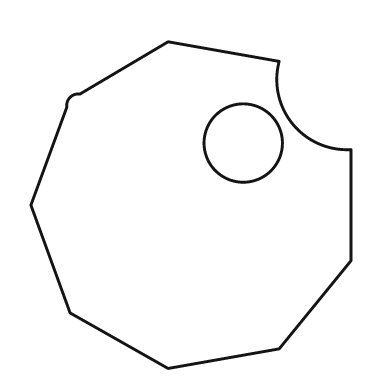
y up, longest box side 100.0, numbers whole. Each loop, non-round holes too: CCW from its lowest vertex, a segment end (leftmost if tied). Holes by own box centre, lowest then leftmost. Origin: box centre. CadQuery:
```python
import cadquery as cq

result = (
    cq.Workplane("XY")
    .moveTo(-7.0, -50.0)
    .lineTo(27.0, -44.0)
    .lineTo(49.0, -17.0)
    .lineTo(49.0, 17.0)
    .threePointArc((31.0, 25.0), (27.0, 44.0))
    .lineTo(-7.0, 50.0)
    .lineTo(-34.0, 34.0)
    .threePointArc((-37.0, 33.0), (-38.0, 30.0))
    .lineTo(-49.0, 0.0)
    .lineTo(-37.0, -33.0)
    .close()
    .moveTo(16.0, 19.0)
    .circle(12.0)
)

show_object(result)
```